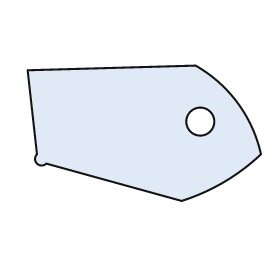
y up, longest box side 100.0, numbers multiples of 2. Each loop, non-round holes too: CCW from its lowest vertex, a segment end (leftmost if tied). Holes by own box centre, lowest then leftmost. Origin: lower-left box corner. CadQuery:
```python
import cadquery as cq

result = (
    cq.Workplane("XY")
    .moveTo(66.0, 0.0)
    .threePointArc((84.0, 8.0), (100.0, 20.0))
    .threePointArc((90.0, 42.0), (72.0, 58.0))
    .lineTo(0.0, 56.0)
    .lineTo(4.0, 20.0)
    .threePointArc((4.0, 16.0), (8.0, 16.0))
    .close()
    .moveTo(74.0, 34.0)
    .circle(6.0)
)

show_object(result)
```